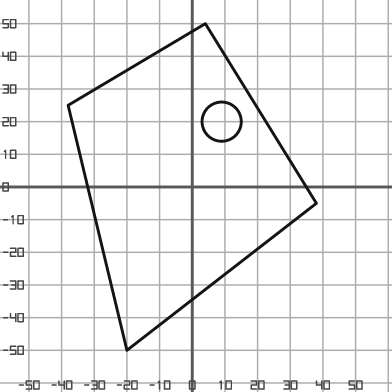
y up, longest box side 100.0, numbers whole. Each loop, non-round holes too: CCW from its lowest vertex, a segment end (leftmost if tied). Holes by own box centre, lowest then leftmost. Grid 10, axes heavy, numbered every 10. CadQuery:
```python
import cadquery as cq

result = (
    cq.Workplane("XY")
    .moveTo(-20.0, -50.0)
    .lineTo(38.0, -5.0)
    .lineTo(4.0, 50.0)
    .lineTo(-38.0, 25.0)
    .close()
    .moveTo(9.0, 20.0)
    .circle(6.0)
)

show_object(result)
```